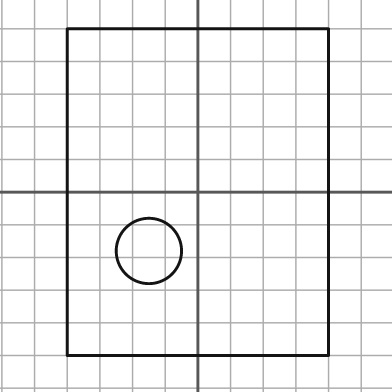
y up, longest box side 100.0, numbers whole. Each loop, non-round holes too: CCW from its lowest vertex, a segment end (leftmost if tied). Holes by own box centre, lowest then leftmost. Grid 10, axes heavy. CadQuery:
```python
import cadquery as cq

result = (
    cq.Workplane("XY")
    .moveTo(-40.0, -50.0)
    .lineTo(40.0, -50.0)
    .lineTo(40.0, 50.0)
    .lineTo(-40.0, 50.0)
    .close()
    .moveTo(-15.0, -18.0)
    .circle(10.0)
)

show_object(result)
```